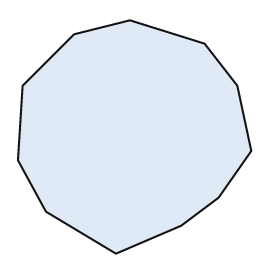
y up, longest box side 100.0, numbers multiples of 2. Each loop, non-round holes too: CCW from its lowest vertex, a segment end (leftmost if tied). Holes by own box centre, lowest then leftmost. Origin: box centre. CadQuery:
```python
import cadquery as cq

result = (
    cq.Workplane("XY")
    .moveTo(-8.0, -50.0)
    .lineTo(20.0, -38.0)
    .lineTo(36.0, -26.0)
    .lineTo(50.0, -6.0)
    .lineTo(44.0, 22.0)
    .lineTo(30.0, 40.0)
    .lineTo(-2.0, 50.0)
    .lineTo(-26.0, 44.0)
    .lineTo(-48.0, 22.0)
    .lineTo(-50.0, -10.0)
    .lineTo(-38.0, -32.0)
    .close()
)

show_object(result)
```